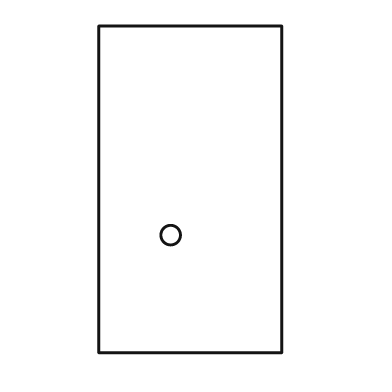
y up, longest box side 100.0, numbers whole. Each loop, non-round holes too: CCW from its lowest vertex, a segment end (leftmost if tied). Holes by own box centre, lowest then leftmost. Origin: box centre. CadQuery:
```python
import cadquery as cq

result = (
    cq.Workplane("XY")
    .moveTo(-28.0, -50.0)
    .lineTo(28.0, -50.0)
    .lineTo(28.0, 50.0)
    .lineTo(-28.0, 50.0)
    .close()
    .moveTo(-6.0, -14.0)
    .circle(3.0)
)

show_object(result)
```